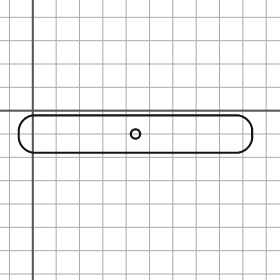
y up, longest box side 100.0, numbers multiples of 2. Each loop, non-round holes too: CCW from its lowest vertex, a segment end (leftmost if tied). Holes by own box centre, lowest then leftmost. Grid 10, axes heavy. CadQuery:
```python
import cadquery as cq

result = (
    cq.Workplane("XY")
    .moveTo(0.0, -18.0)
    .lineTo(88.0, -18.0)
    .threePointArc((92.0, -16.0), (94.0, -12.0))
    .lineTo(94.0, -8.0)
    .threePointArc((92.0, -4.0), (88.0, -2.0))
    .lineTo(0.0, -2.0)
    .threePointArc((-4.0, -4.0), (-6.0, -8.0))
    .lineTo(-6.0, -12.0)
    .threePointArc((-4.0, -16.0), (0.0, -18.0))
    .close()
    .moveTo(44.0, -10.0)
    .circle(2.0)
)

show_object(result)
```